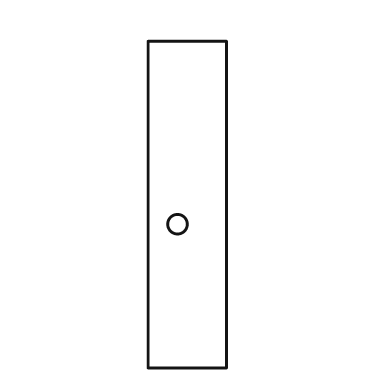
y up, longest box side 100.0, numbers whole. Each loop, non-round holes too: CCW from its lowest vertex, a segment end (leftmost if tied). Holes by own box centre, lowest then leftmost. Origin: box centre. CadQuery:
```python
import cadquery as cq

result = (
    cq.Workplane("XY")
    .moveTo(-12.0, -50.0)
    .lineTo(12.0, -50.0)
    .lineTo(12.0, 50.0)
    .lineTo(-12.0, 50.0)
    .close()
    .moveTo(-3.0, -6.0)
    .circle(3.0)
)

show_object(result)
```